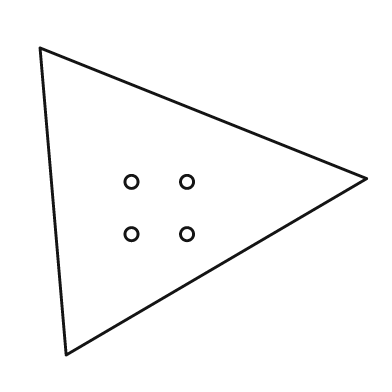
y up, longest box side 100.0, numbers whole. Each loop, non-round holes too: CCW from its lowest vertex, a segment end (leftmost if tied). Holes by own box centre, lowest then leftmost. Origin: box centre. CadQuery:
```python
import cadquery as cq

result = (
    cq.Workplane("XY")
    .moveTo(-42.0, -47.0)
    .lineTo(50.0, 7.0)
    .lineTo(-50.0, 47.0)
    .close()
    .moveTo(-22.0, -10.0)
    .circle(2.0)
    .moveTo(-5.0, -10.0)
    .circle(2.0)
    .moveTo(-22.0, 6.0)
    .circle(2.0)
    .moveTo(-5.0, 6.0)
    .circle(2.0)
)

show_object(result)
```